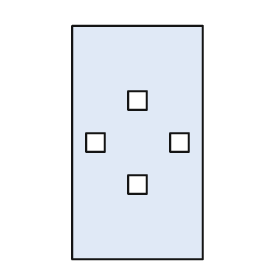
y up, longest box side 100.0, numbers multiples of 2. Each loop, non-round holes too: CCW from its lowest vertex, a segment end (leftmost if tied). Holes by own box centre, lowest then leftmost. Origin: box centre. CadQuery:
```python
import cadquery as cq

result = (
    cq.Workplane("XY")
    .moveTo(-28.0, -50.0)
    .lineTo(28.0, -50.0)
    .lineTo(28.0, 50.0)
    .lineTo(-28.0, 50.0)
    .close()
    .moveTo(-4.0, -22.0)
    .lineTo(4.0, -22.0)
    .lineTo(4.0, -14.0)
    .lineTo(-4.0, -14.0)
    .close()
    .moveTo(-22.0, -4.0)
    .lineTo(-14.0, -4.0)
    .lineTo(-14.0, 4.0)
    .lineTo(-22.0, 4.0)
    .close()
    .moveTo(14.0, -4.0)
    .lineTo(22.0, -4.0)
    .lineTo(22.0, 4.0)
    .lineTo(14.0, 4.0)
    .close()
    .moveTo(-4.0, 14.0)
    .lineTo(4.0, 14.0)
    .lineTo(4.0, 22.0)
    .lineTo(-4.0, 22.0)
    .close()
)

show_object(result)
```